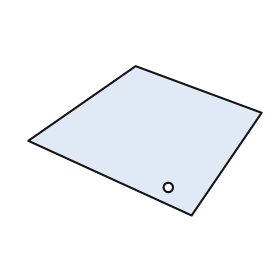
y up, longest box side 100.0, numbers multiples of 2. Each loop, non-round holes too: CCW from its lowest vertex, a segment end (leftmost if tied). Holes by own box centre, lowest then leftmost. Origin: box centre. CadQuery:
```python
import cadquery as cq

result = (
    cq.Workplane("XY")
    .moveTo(20.0, -32.0)
    .lineTo(50.0, 12.0)
    .lineTo(-4.0, 32.0)
    .lineTo(-50.0, 0.0)
    .close()
    .moveTo(10.0, -20.0)
    .circle(2.0)
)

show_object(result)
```